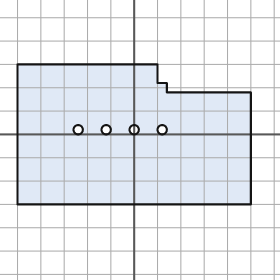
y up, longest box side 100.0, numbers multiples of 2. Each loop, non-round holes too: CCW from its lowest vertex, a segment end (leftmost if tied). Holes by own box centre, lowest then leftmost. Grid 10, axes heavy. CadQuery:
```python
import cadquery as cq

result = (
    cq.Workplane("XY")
    .moveTo(-50.0, -30.0)
    .lineTo(50.0, -30.0)
    .lineTo(50.0, 18.0)
    .lineTo(14.0, 18.0)
    .lineTo(14.0, 22.0)
    .lineTo(10.0, 22.0)
    .lineTo(10.0, 30.0)
    .lineTo(-50.0, 30.0)
    .close()
    .moveTo(-24.0, 2.0)
    .circle(2.0)
    .moveTo(-12.0, 2.0)
    .circle(2.0)
    .moveTo(0.0, 2.0)
    .circle(2.0)
    .moveTo(12.0, 2.0)
    .circle(2.0)
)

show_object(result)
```